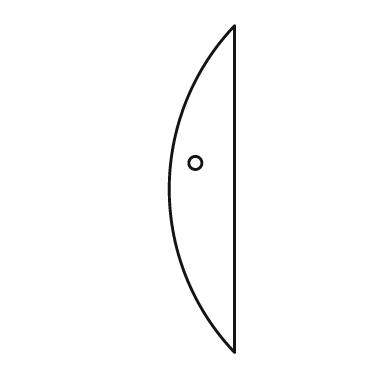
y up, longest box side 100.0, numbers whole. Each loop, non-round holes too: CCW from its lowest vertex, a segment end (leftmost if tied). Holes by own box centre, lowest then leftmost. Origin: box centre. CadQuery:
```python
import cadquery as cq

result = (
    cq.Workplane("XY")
    .moveTo(10.0, -50.0)
    .lineTo(10.0, 50.0)
    .threePointArc((-10.0, 0.0), (10.0, -50.0))
    .close()
    .moveTo(-2.0, 8.0)
    .circle(2.0)
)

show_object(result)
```